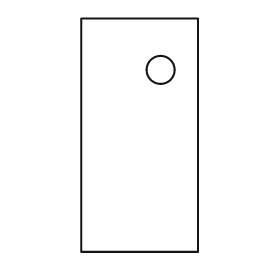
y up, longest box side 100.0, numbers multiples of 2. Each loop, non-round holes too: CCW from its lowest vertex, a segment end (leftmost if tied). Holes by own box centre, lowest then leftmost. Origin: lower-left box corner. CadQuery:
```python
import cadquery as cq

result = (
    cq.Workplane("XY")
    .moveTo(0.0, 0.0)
    .lineTo(50.0, 0.0)
    .lineTo(50.0, 100.0)
    .lineTo(0.0, 100.0)
    .close()
    .moveTo(34.0, 78.0)
    .circle(6.0)
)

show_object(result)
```